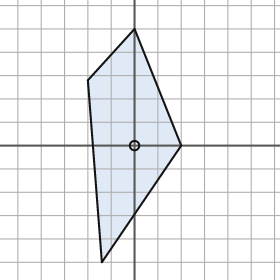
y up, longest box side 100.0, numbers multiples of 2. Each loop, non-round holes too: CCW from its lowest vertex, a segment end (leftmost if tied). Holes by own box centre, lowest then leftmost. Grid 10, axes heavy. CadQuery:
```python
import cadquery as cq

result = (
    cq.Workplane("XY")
    .moveTo(-14.0, -50.0)
    .lineTo(20.0, 0.0)
    .lineTo(0.0, 50.0)
    .lineTo(-20.0, 28.0)
    .close()
    .moveTo(0.0, 0.0)
    .circle(2.0)
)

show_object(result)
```